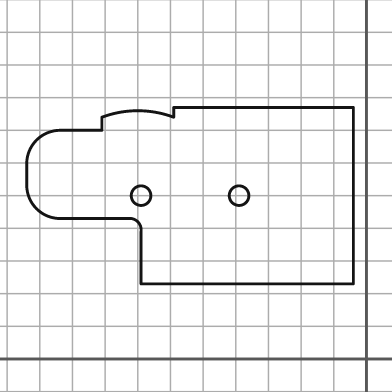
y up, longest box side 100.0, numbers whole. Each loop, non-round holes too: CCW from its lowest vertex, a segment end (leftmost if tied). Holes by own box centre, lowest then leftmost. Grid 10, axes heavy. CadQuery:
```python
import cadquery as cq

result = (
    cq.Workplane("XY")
    .moveTo(-69.0, 23.0)
    .lineTo(-4.0, 23.0)
    .lineTo(-4.0, 77.0)
    .lineTo(-59.0, 77.0)
    .lineTo(-59.0, 74.0)
    .threePointArc((-70.0, 76.0), (-81.0, 74.0))
    .lineTo(-81.0, 70.0)
    .lineTo(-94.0, 70.0)
    .threePointArc((-101.0, 67.0), (-104.0, 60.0))
    .lineTo(-104.0, 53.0)
    .threePointArc((-101.0, 46.0), (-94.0, 43.0))
    .lineTo(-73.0, 43.0)
    .threePointArc((-70.0, 42.0), (-69.0, 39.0))
    .close()
    .moveTo(-69.0, 50.0)
    .circle(3.0)
    .moveTo(-39.0, 50.0)
    .circle(3.0)
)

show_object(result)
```